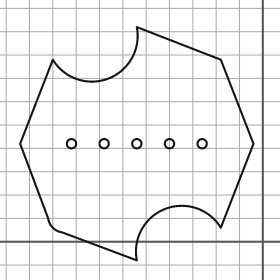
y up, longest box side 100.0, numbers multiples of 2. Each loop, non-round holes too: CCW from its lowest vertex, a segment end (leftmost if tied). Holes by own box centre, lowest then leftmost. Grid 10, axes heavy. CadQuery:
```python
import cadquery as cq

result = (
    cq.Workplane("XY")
    .moveTo(-54.0, -8.0)
    .threePointArc((-42.0, 14.0), (-18.0, 6.0))
    .lineTo(-4.0, 42.0)
    .lineTo(-18.0, 78.0)
    .lineTo(-54.0, 92.0)
    .threePointArc((-66.0, 70.0), (-90.0, 78.0))
    .lineTo(-104.0, 42.0)
    .lineTo(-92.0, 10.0)
    .threePointArc((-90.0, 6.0), (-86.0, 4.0))
    .close()
    .moveTo(-82.0, 42.0)
    .circle(2.0)
    .moveTo(-68.0, 42.0)
    .circle(2.0)
    .moveTo(-54.0, 42.0)
    .circle(2.0)
    .moveTo(-40.0, 42.0)
    .circle(2.0)
    .moveTo(-26.0, 42.0)
    .circle(2.0)
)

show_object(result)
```